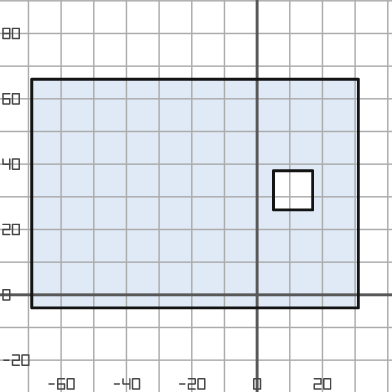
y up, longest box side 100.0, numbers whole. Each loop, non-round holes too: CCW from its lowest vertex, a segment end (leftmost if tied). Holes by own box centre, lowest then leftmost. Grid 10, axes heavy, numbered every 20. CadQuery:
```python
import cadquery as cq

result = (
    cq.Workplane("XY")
    .moveTo(-69.0, -4.0)
    .lineTo(31.0, -4.0)
    .lineTo(31.0, 66.0)
    .lineTo(-69.0, 66.0)
    .close()
    .moveTo(5.0, 26.0)
    .lineTo(17.0, 26.0)
    .lineTo(17.0, 38.0)
    .lineTo(5.0, 38.0)
    .close()
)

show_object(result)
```